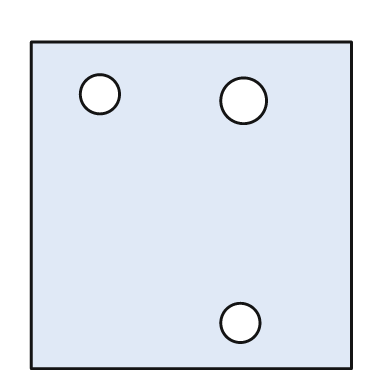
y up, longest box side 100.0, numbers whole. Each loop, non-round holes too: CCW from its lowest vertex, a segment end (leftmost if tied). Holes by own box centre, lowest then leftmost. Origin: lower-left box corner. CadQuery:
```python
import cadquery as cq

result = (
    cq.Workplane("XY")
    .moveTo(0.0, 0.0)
    .lineTo(98.0, 0.0)
    .lineTo(98.0, 100.0)
    .lineTo(0.0, 100.0)
    .close()
    .moveTo(64.0, 14.0)
    .circle(6.0)
    .moveTo(65.0, 82.0)
    .circle(7.0)
    .moveTo(21.0, 84.0)
    .circle(6.0)
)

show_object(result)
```